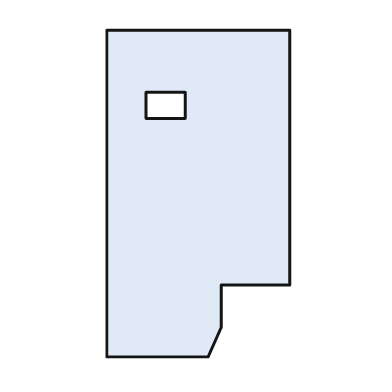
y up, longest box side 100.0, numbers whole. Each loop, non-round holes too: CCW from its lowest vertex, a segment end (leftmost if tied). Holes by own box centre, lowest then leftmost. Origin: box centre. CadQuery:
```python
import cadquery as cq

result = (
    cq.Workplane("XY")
    .moveTo(-28.0, -50.0)
    .lineTo(3.0, -50.0)
    .lineTo(7.0, -41.0)
    .lineTo(7.0, -28.0)
    .lineTo(28.0, -28.0)
    .lineTo(28.0, 50.0)
    .lineTo(-28.0, 50.0)
    .close()
    .moveTo(-16.0, 23.0)
    .lineTo(-4.0, 23.0)
    .lineTo(-4.0, 31.0)
    .lineTo(-16.0, 31.0)
    .close()
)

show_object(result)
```